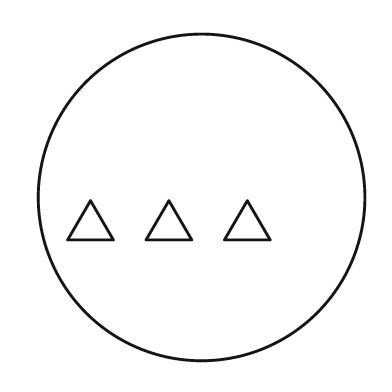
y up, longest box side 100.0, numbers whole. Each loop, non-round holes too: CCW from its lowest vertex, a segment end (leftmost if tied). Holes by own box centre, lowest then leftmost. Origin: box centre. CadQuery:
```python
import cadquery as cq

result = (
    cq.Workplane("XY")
    .moveTo(0.0, 0.0)
    .circle(50.0)
    .moveTo(-41.0, -13.0)
    .lineTo(-27.0, -13.0)
    .lineTo(-34.0, -1.0)
    .close()
    .moveTo(-17.0, -13.0)
    .lineTo(-3.0, -13.0)
    .lineTo(-10.0, -1.0)
    .close()
    .moveTo(7.0, -13.0)
    .lineTo(21.0, -13.0)
    .lineTo(14.0, -1.0)
    .close()
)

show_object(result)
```